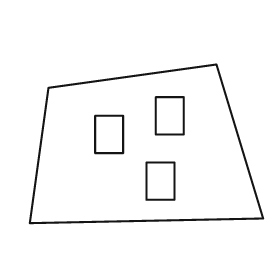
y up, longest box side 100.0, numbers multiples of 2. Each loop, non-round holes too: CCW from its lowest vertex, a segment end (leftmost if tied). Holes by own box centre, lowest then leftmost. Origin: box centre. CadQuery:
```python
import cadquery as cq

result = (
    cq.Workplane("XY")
    .moveTo(-50.0, -34.0)
    .lineTo(50.0, -32.0)
    .lineTo(30.0, 34.0)
    .lineTo(-42.0, 24.0)
    .close()
    .moveTo(0.0, -24.0)
    .lineTo(12.0, -24.0)
    .lineTo(12.0, -8.0)
    .lineTo(0.0, -8.0)
    .close()
    .moveTo(-22.0, -4.0)
    .lineTo(-10.0, -4.0)
    .lineTo(-10.0, 12.0)
    .lineTo(-22.0, 12.0)
    .close()
    .moveTo(4.0, 4.0)
    .lineTo(16.0, 4.0)
    .lineTo(16.0, 20.0)
    .lineTo(4.0, 20.0)
    .close()
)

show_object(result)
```